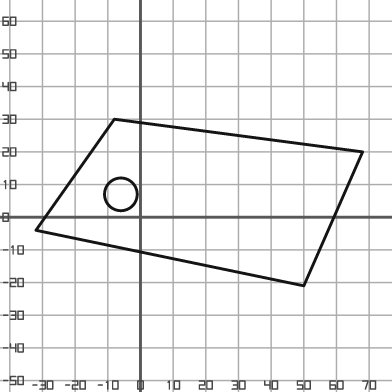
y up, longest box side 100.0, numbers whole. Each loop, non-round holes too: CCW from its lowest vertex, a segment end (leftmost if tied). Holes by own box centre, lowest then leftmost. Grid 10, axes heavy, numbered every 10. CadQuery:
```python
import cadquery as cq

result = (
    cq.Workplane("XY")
    .moveTo(50.0, -21.0)
    .lineTo(68.0, 20.0)
    .lineTo(-8.0, 30.0)
    .lineTo(-32.0, -4.0)
    .close()
    .moveTo(-6.0, 7.0)
    .circle(5.0)
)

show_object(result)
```